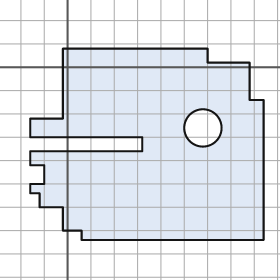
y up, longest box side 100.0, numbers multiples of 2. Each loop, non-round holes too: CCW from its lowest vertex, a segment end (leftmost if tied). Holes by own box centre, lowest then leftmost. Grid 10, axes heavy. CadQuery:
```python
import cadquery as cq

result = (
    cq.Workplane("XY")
    .moveTo(6.0, -74.0)
    .lineTo(84.0, -74.0)
    .lineTo(84.0, -14.0)
    .lineTo(78.0, -14.0)
    .lineTo(78.0, 2.0)
    .lineTo(60.0, 2.0)
    .lineTo(60.0, 8.0)
    .lineTo(-2.0, 8.0)
    .lineTo(-2.0, -22.0)
    .lineTo(-16.0, -22.0)
    .lineTo(-16.0, -30.0)
    .lineTo(32.0, -30.0)
    .lineTo(32.0, -36.0)
    .lineTo(-16.0, -36.0)
    .lineTo(-16.0, -42.0)
    .lineTo(-10.0, -42.0)
    .lineTo(-10.0, -50.0)
    .lineTo(-16.0, -50.0)
    .lineTo(-16.0, -54.0)
    .lineTo(-12.0, -54.0)
    .lineTo(-12.0, -60.0)
    .lineTo(-2.0, -60.0)
    .lineTo(-2.0, -70.0)
    .lineTo(6.0, -70.0)
    .close()
    .moveTo(58.0, -26.0)
    .circle(8.0)
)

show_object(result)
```